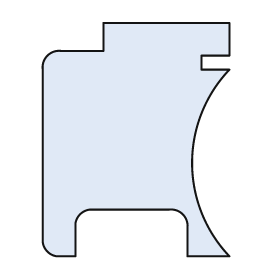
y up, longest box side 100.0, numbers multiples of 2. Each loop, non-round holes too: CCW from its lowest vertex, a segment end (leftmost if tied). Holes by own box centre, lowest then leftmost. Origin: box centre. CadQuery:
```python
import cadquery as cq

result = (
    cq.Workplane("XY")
    .moveTo(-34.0, -50.0)
    .lineTo(-26.0, -50.0)
    .lineTo(-26.0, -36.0)
    .threePointArc((-24.0, -32.0), (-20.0, -30.0))
    .lineTo(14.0, -30.0)
    .threePointArc((20.0, -32.0), (22.0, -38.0))
    .lineTo(22.0, -50.0)
    .lineTo(40.0, -50.0)
    .threePointArc((24.0, -10.0), (40.0, 30.0))
    .lineTo(28.0, 30.0)
    .lineTo(28.0, 36.0)
    .lineTo(40.0, 36.0)
    .lineTo(40.0, 50.0)
    .lineTo(-14.0, 50.0)
    .lineTo(-14.0, 38.0)
    .lineTo(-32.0, 38.0)
    .threePointArc((-38.0, 36.0), (-40.0, 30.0))
    .lineTo(-40.0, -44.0)
    .threePointArc((-38.0, -48.0), (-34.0, -50.0))
    .close()
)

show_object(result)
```